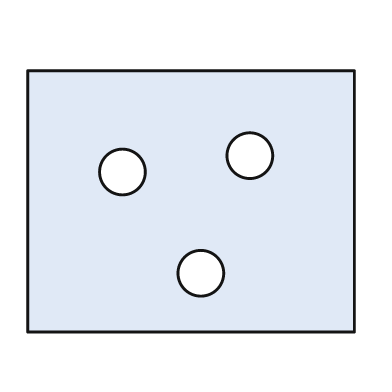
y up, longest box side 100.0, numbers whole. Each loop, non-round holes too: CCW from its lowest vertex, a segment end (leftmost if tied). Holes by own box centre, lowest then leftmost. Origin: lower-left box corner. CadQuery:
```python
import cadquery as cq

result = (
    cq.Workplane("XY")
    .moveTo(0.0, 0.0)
    .lineTo(100.0, 0.0)
    .lineTo(100.0, 80.0)
    .lineTo(0.0, 80.0)
    .close()
    .moveTo(53.0, 18.0)
    .circle(7.0)
    .moveTo(29.0, 49.0)
    .circle(7.0)
    .moveTo(68.0, 54.0)
    .circle(7.0)
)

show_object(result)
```